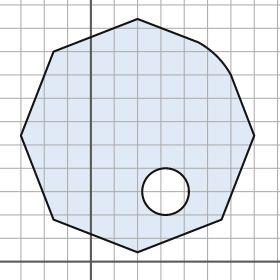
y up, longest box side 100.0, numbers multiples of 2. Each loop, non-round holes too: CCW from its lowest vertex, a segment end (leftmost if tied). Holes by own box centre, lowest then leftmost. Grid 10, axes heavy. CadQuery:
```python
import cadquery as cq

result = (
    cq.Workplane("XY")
    .moveTo(20.0, 4.0)
    .lineTo(56.0, 18.0)
    .lineTo(70.0, 54.0)
    .lineTo(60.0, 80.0)
    .threePointArc((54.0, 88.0), (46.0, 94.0))
    .lineTo(20.0, 104.0)
    .lineTo(-16.0, 90.0)
    .lineTo(-30.0, 54.0)
    .lineTo(-16.0, 18.0)
    .close()
    .moveTo(32.0, 30.0)
    .circle(10.0)
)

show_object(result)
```